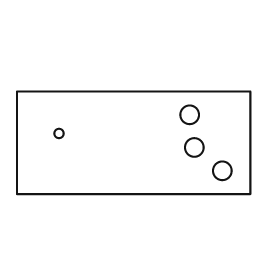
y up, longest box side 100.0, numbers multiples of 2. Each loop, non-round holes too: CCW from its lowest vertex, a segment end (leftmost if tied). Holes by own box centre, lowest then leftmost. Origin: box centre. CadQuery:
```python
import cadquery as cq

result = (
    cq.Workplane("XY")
    .moveTo(-50.0, -22.0)
    .lineTo(50.0, -22.0)
    .lineTo(50.0, 22.0)
    .lineTo(-50.0, 22.0)
    .close()
    .moveTo(38.0, -12.0)
    .circle(4.0)
    .moveTo(26.0, -2.0)
    .circle(4.0)
    .moveTo(-32.0, 4.0)
    .circle(2.0)
    .moveTo(24.0, 12.0)
    .circle(4.0)
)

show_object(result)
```